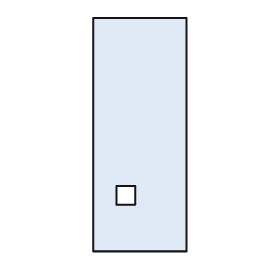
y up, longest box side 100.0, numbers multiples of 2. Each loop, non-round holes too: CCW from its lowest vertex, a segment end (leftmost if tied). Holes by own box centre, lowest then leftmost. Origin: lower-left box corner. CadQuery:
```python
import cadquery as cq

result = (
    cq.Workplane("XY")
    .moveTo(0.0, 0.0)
    .lineTo(40.0, 0.0)
    .lineTo(40.0, 100.0)
    .lineTo(0.0, 100.0)
    .close()
    .moveTo(10.0, 20.0)
    .lineTo(18.0, 20.0)
    .lineTo(18.0, 28.0)
    .lineTo(10.0, 28.0)
    .close()
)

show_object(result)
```